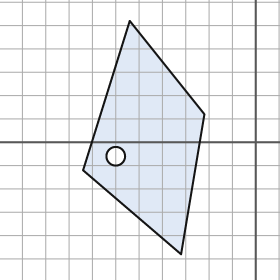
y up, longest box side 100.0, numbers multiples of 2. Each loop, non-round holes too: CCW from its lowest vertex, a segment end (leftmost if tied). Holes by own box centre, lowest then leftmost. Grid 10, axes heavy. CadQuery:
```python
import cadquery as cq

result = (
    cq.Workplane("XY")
    .moveTo(-32.0, -48.0)
    .lineTo(-22.0, 12.0)
    .lineTo(-54.0, 52.0)
    .lineTo(-74.0, -12.0)
    .close()
    .moveTo(-60.0, -6.0)
    .circle(4.0)
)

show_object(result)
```